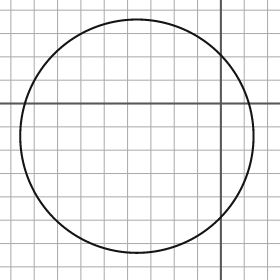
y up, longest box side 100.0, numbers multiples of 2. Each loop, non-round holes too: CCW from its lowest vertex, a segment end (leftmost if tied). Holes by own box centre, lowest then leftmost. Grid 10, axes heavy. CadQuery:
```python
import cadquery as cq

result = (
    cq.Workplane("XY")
    .moveTo(-36.0, -14.0)
    .circle(50.0)
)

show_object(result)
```